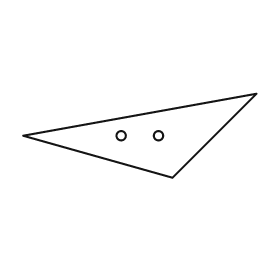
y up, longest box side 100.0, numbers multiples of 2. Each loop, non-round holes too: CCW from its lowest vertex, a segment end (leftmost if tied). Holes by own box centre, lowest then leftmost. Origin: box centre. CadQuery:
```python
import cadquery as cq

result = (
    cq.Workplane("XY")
    .moveTo(14.0, -18.0)
    .lineTo(50.0, 18.0)
    .lineTo(-50.0, 0.0)
    .close()
    .moveTo(-8.0, 0.0)
    .circle(2.0)
    .moveTo(8.0, 0.0)
    .circle(2.0)
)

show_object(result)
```